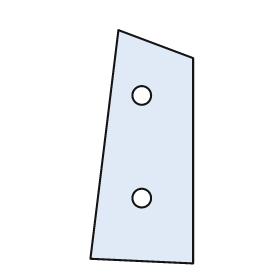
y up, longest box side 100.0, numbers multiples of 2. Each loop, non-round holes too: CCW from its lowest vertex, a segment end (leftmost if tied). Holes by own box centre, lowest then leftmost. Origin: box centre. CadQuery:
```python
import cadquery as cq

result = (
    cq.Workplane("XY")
    .moveTo(22.0, -50.0)
    .lineTo(22.0, 38.0)
    .lineTo(-10.0, 50.0)
    .lineTo(-22.0, -48.0)
    .close()
    .moveTo(0.0, -22.0)
    .circle(4.0)
    .moveTo(0.0, 22.0)
    .circle(4.0)
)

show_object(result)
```